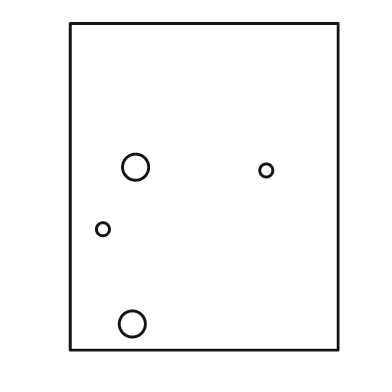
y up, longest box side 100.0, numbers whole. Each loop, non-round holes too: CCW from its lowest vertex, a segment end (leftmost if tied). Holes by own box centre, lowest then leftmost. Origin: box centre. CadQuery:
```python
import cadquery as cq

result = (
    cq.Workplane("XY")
    .moveTo(-41.0, -50.0)
    .lineTo(41.0, -50.0)
    .lineTo(41.0, 50.0)
    .lineTo(-41.0, 50.0)
    .close()
    .moveTo(-22.0, -42.0)
    .circle(4.0)
    .moveTo(-31.0, -13.0)
    .circle(2.0)
    .moveTo(19.0, 5.0)
    .circle(2.0)
    .moveTo(-21.0, 6.0)
    .circle(4.0)
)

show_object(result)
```